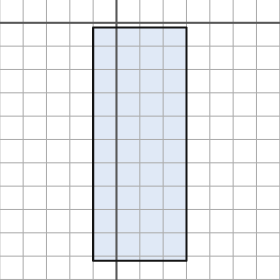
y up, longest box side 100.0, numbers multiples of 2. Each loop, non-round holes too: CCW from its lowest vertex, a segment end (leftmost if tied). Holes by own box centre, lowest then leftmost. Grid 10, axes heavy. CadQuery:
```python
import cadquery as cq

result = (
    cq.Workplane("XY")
    .moveTo(-10.0, -102.0)
    .lineTo(30.0, -102.0)
    .lineTo(30.0, -2.0)
    .lineTo(-10.0, -2.0)
    .close()
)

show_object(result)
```